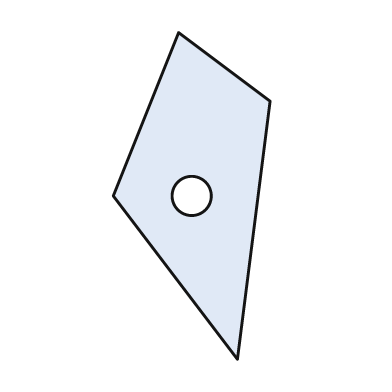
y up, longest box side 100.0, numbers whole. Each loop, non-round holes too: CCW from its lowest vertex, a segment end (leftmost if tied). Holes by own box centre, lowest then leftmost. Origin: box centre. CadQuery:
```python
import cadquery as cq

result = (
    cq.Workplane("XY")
    .moveTo(14.0, -50.0)
    .lineTo(24.0, 29.0)
    .lineTo(-4.0, 50.0)
    .lineTo(-24.0, 0.0)
    .close()
    .moveTo(0.0, 0.0)
    .circle(6.0)
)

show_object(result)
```